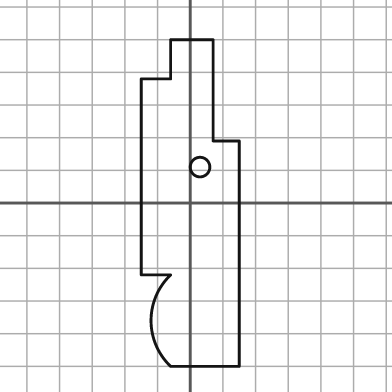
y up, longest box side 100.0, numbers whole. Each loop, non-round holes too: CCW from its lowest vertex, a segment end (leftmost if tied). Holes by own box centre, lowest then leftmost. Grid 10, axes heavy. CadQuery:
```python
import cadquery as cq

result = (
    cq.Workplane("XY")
    .moveTo(-6.0, -50.0)
    .lineTo(15.0, -50.0)
    .lineTo(15.0, 19.0)
    .lineTo(7.0, 19.0)
    .lineTo(7.0, 50.0)
    .lineTo(-6.0, 50.0)
    .lineTo(-6.0, 38.0)
    .lineTo(-15.0, 38.0)
    .lineTo(-15.0, -22.0)
    .lineTo(-6.0, -22.0)
    .threePointArc((-12.0, -36.0), (-6.0, -50.0))
    .close()
    .moveTo(3.0, 11.0)
    .circle(3.0)
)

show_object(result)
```